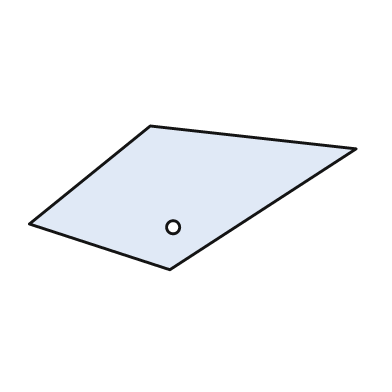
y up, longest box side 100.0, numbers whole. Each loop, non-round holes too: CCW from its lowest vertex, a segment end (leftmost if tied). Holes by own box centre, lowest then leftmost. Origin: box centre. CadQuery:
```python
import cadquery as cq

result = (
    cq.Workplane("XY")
    .moveTo(-7.0, -22.0)
    .lineTo(50.0, 15.0)
    .lineTo(-13.0, 22.0)
    .lineTo(-50.0, -8.0)
    .close()
    .moveTo(-6.0, -9.0)
    .circle(2.0)
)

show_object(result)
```